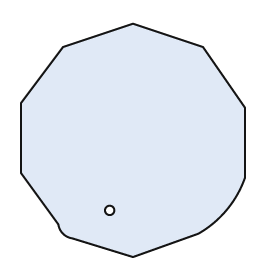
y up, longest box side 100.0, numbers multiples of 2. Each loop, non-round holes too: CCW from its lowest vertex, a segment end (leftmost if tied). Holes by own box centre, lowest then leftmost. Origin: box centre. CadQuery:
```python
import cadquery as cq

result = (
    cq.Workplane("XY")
    .moveTo(0.0, -50.0)
    .lineTo(28.0, -40.0)
    .threePointArc((40.0, -30.0), (48.0, -16.0))
    .lineTo(48.0, 14.0)
    .lineTo(30.0, 40.0)
    .lineTo(0.0, 50.0)
    .lineTo(-30.0, 40.0)
    .lineTo(-48.0, 16.0)
    .lineTo(-48.0, -14.0)
    .lineTo(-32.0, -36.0)
    .threePointArc((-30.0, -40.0), (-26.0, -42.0))
    .close()
    .moveTo(-10.0, -30.0)
    .circle(2.0)
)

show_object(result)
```